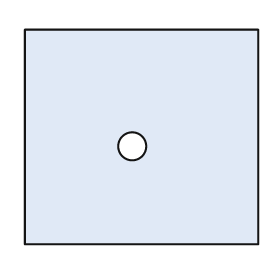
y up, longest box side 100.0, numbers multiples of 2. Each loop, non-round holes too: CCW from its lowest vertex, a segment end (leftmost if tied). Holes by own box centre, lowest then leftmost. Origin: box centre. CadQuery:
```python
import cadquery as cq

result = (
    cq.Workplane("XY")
    .moveTo(-50.0, -46.0)
    .lineTo(50.0, -46.0)
    .lineTo(50.0, 46.0)
    .lineTo(-50.0, 46.0)
    .close()
    .moveTo(-4.0, -4.0)
    .circle(6.0)
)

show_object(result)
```